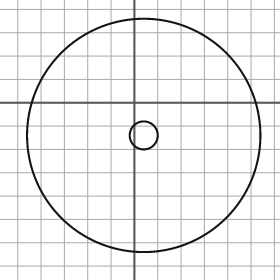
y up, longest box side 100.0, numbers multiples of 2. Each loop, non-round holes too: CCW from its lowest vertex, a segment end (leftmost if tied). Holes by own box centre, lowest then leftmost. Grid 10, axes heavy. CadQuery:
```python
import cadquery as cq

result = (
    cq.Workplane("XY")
    .moveTo(4.0, -14.0)
    .circle(50.0)
    .moveTo(4.0, -14.0)
    .circle(6.0)
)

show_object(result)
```